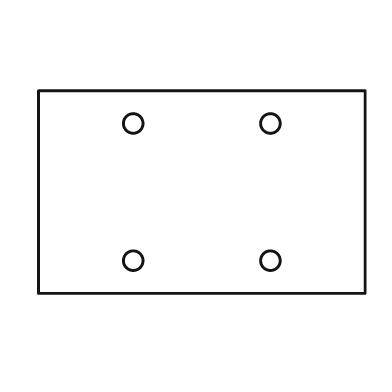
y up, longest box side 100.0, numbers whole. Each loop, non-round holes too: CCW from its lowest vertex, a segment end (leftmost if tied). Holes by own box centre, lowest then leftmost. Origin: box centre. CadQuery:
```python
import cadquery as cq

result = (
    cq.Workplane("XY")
    .moveTo(-50.0, -31.0)
    .lineTo(50.0, -31.0)
    .lineTo(50.0, 31.0)
    .lineTo(-50.0, 31.0)
    .close()
    .moveTo(-21.0, -21.0)
    .circle(3.0)
    .moveTo(21.0, -21.0)
    .circle(3.0)
    .moveTo(-21.0, 21.0)
    .circle(3.0)
    .moveTo(21.0, 21.0)
    .circle(3.0)
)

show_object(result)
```